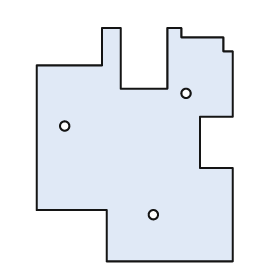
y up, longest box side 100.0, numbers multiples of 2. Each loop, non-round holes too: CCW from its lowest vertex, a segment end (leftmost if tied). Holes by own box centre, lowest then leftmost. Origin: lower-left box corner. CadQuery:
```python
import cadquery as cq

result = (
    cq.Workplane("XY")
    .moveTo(30.0, 0.0)
    .lineTo(84.0, 0.0)
    .lineTo(84.0, 40.0)
    .lineTo(70.0, 40.0)
    .lineTo(70.0, 62.0)
    .lineTo(84.0, 62.0)
    .lineTo(84.0, 90.0)
    .lineTo(80.0, 90.0)
    .lineTo(80.0, 96.0)
    .lineTo(62.0, 96.0)
    .lineTo(62.0, 100.0)
    .lineTo(56.0, 100.0)
    .lineTo(56.0, 74.0)
    .lineTo(36.0, 74.0)
    .lineTo(36.0, 100.0)
    .lineTo(28.0, 100.0)
    .lineTo(28.0, 84.0)
    .lineTo(0.0, 84.0)
    .lineTo(0.0, 22.0)
    .lineTo(30.0, 22.0)
    .close()
    .moveTo(50.0, 20.0)
    .circle(2.0)
    .moveTo(12.0, 58.0)
    .circle(2.0)
    .moveTo(64.0, 72.0)
    .circle(2.0)
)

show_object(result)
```